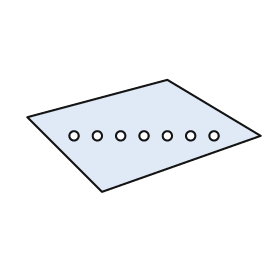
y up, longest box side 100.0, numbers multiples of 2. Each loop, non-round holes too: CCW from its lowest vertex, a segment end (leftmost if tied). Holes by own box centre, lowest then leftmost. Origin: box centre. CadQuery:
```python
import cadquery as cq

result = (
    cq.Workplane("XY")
    .moveTo(-18.0, -24.0)
    .lineTo(50.0, 0.0)
    .lineTo(10.0, 24.0)
    .lineTo(-50.0, 8.0)
    .close()
    .moveTo(-30.0, 0.0)
    .circle(2.0)
    .moveTo(-20.0, 0.0)
    .circle(2.0)
    .moveTo(-10.0, 0.0)
    .circle(2.0)
    .moveTo(0.0, 0.0)
    .circle(2.0)
    .moveTo(10.0, 0.0)
    .circle(2.0)
    .moveTo(20.0, 0.0)
    .circle(2.0)
    .moveTo(30.0, 0.0)
    .circle(2.0)
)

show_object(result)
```